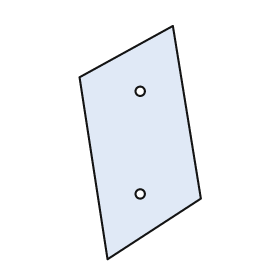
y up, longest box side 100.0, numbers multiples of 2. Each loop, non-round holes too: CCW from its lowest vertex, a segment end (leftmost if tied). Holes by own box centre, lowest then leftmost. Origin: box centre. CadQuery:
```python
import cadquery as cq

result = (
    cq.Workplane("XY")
    .moveTo(-14.0, -50.0)
    .lineTo(26.0, -24.0)
    .lineTo(14.0, 50.0)
    .lineTo(-26.0, 28.0)
    .close()
    .moveTo(0.0, -22.0)
    .circle(2.0)
    .moveTo(0.0, 22.0)
    .circle(2.0)
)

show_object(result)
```